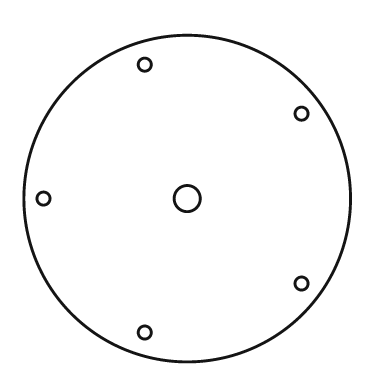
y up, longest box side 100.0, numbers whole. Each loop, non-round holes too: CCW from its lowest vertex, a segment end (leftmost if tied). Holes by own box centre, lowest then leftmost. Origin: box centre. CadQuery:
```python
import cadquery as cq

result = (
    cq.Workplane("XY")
    .moveTo(0.0, 0.0)
    .circle(50.0)
    .moveTo(-13.0, -41.0)
    .circle(2.0)
    .moveTo(35.0, -26.0)
    .circle(2.0)
    .moveTo(-44.0, 0.0)
    .circle(2.0)
    .moveTo(0.0, 0.0)
    .circle(4.0)
    .moveTo(35.0, 26.0)
    .circle(2.0)
    .moveTo(-13.0, 41.0)
    .circle(2.0)
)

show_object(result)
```